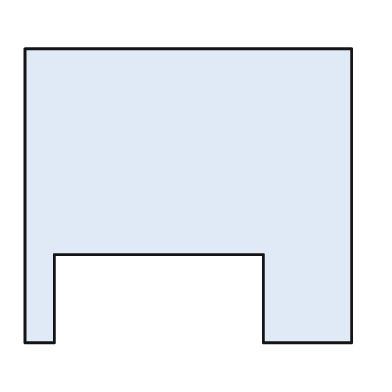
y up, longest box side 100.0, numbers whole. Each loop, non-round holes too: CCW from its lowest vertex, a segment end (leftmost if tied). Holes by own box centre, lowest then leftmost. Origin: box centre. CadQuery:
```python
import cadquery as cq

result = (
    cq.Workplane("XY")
    .moveTo(-50.0, -45.0)
    .lineTo(-41.0, -45.0)
    .lineTo(-41.0, -18.0)
    .lineTo(23.0, -18.0)
    .lineTo(23.0, -45.0)
    .lineTo(50.0, -45.0)
    .lineTo(50.0, 45.0)
    .lineTo(-50.0, 45.0)
    .close()
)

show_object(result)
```